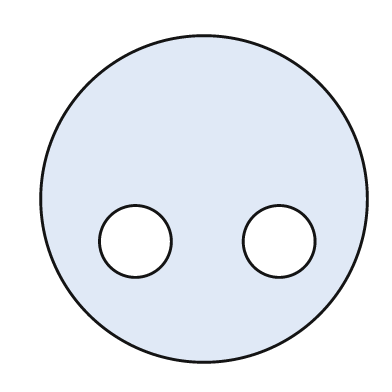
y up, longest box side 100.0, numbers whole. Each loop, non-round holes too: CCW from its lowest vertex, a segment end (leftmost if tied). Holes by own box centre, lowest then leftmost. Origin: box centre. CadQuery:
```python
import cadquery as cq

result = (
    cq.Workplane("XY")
    .moveTo(0.0, 0.0)
    .circle(50.0)
    .moveTo(-21.0, -13.0)
    .circle(11.0)
    .moveTo(23.0, -13.0)
    .circle(11.0)
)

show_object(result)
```